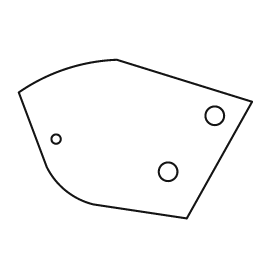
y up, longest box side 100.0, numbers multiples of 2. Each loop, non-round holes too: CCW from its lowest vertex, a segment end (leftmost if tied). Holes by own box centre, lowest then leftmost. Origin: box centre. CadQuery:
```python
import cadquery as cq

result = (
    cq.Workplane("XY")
    .moveTo(22.0, -34.0)
    .lineTo(50.0, 16.0)
    .lineTo(-8.0, 34.0)
    .threePointArc((-30.0, 30.0), (-50.0, 20.0))
    .lineTo(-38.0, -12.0)
    .threePointArc((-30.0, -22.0), (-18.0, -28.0))
    .close()
    .moveTo(14.0, -14.0)
    .circle(4.0)
    .moveTo(-34.0, 0.0)
    .circle(2.0)
    .moveTo(34.0, 10.0)
    .circle(4.0)
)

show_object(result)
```